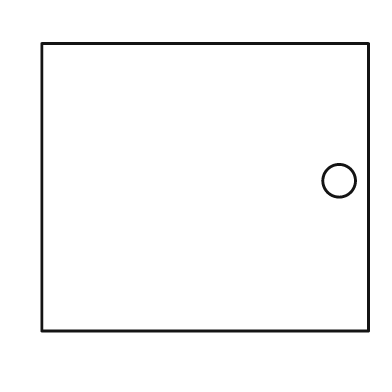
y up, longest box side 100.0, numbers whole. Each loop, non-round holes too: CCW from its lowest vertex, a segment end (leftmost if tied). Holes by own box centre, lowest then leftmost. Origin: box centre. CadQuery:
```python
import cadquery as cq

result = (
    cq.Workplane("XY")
    .moveTo(-50.0, -44.0)
    .lineTo(50.0, -44.0)
    .lineTo(50.0, 44.0)
    .lineTo(-50.0, 44.0)
    .close()
    .moveTo(41.0, 2.0)
    .circle(5.0)
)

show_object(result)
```